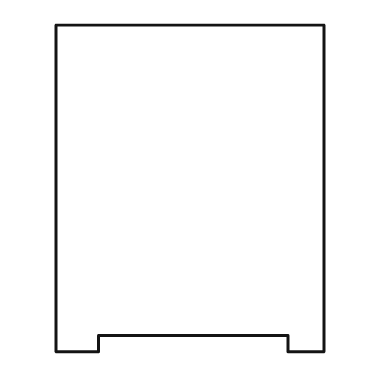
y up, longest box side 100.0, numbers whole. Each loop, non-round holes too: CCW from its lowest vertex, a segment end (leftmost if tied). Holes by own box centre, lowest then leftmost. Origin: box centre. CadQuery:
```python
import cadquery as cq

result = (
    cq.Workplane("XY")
    .moveTo(-41.0, -50.0)
    .lineTo(-28.0, -50.0)
    .lineTo(-28.0, -45.0)
    .lineTo(30.0, -45.0)
    .lineTo(30.0, -50.0)
    .lineTo(41.0, -50.0)
    .lineTo(41.0, 50.0)
    .lineTo(-41.0, 50.0)
    .close()
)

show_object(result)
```